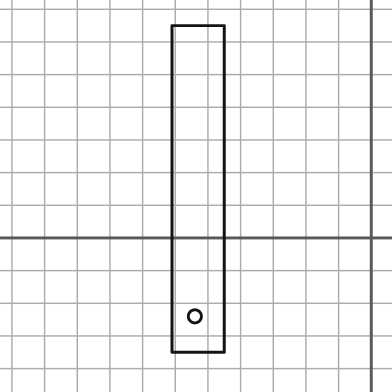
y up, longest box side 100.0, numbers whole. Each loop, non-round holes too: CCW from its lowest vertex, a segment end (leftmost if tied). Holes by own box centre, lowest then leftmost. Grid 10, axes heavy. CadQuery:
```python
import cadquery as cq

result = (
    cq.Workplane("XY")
    .moveTo(-61.0, -35.0)
    .lineTo(-45.0, -35.0)
    .lineTo(-45.0, 65.0)
    .lineTo(-61.0, 65.0)
    .close()
    .moveTo(-54.0, -24.0)
    .circle(2.0)
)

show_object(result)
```